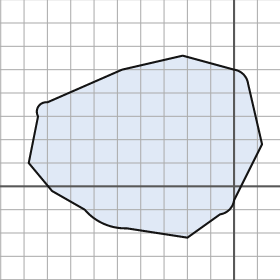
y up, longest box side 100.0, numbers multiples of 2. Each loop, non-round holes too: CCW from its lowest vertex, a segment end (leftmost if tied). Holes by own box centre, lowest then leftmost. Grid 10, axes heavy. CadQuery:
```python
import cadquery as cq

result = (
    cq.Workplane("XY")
    .moveTo(-20.0, -22.0)
    .lineTo(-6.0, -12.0)
    .threePointArc((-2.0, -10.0), (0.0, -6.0))
    .lineTo(12.0, 18.0)
    .lineTo(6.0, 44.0)
    .threePointArc((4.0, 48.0), (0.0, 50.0))
    .lineTo(-22.0, 56.0)
    .lineTo(-48.0, 50.0)
    .lineTo(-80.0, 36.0)
    .threePointArc((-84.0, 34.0), (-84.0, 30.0))
    .lineTo(-88.0, 10.0)
    .lineTo(-78.0, -2.0)
    .lineTo(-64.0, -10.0)
    .threePointArc((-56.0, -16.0), (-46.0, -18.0))
    .close()
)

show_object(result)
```